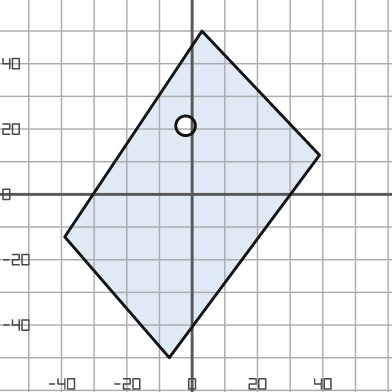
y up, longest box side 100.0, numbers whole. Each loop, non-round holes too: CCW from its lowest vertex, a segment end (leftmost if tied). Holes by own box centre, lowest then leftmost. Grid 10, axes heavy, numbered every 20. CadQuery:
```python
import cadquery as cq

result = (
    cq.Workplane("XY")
    .moveTo(-7.0, -50.0)
    .lineTo(39.0, 12.0)
    .lineTo(3.0, 50.0)
    .lineTo(-39.0, -13.0)
    .close()
    .moveTo(-2.0, 21.0)
    .circle(3.0)
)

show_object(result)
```